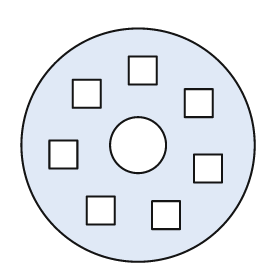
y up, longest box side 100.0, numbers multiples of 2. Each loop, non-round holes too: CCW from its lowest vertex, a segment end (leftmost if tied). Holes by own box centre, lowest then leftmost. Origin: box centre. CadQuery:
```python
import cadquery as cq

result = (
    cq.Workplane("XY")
    .moveTo(0.0, 0.0)
    .circle(50.0)
    .moveTo(6.0, -36.0)
    .lineTo(18.0, -36.0)
    .lineTo(18.0, -24.0)
    .lineTo(6.0, -24.0)
    .close()
    .moveTo(-22.0, -34.0)
    .lineTo(-10.0, -34.0)
    .lineTo(-10.0, -22.0)
    .lineTo(-22.0, -22.0)
    .close()
    .moveTo(24.0, -16.0)
    .lineTo(36.0, -16.0)
    .lineTo(36.0, -4.0)
    .lineTo(24.0, -4.0)
    .close()
    .moveTo(-38.0, -10.0)
    .lineTo(-26.0, -10.0)
    .lineTo(-26.0, 2.0)
    .lineTo(-38.0, 2.0)
    .close()
    .moveTo(0.0, 0.0)
    .circle(12.0)
    .moveTo(20.0, 12.0)
    .lineTo(32.0, 12.0)
    .lineTo(32.0, 24.0)
    .lineTo(20.0, 24.0)
    .close()
    .moveTo(-28.0, 16.0)
    .lineTo(-16.0, 16.0)
    .lineTo(-16.0, 28.0)
    .lineTo(-28.0, 28.0)
    .close()
    .moveTo(-4.0, 26.0)
    .lineTo(8.0, 26.0)
    .lineTo(8.0, 38.0)
    .lineTo(-4.0, 38.0)
    .close()
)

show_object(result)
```